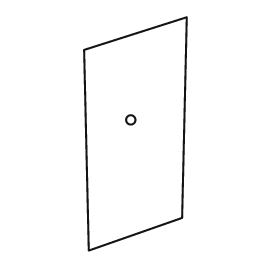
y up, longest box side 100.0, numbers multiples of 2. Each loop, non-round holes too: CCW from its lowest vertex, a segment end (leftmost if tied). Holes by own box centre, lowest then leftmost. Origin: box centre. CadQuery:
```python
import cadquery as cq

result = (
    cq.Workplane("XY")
    .moveTo(-20.0, -50.0)
    .lineTo(20.0, -36.0)
    .lineTo(22.0, 50.0)
    .lineTo(-22.0, 36.0)
    .close()
    .moveTo(-2.0, 6.0)
    .circle(2.0)
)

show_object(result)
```